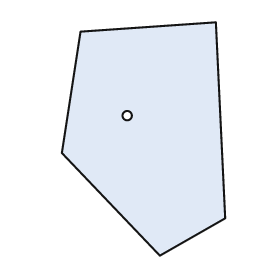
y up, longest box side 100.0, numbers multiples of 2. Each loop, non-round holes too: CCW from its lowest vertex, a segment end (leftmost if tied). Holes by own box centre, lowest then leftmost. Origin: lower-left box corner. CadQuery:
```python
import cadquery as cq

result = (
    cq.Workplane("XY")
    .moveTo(42.0, 0.0)
    .lineTo(70.0, 16.0)
    .lineTo(66.0, 100.0)
    .lineTo(8.0, 96.0)
    .lineTo(0.0, 44.0)
    .close()
    .moveTo(28.0, 60.0)
    .circle(2.0)
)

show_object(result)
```